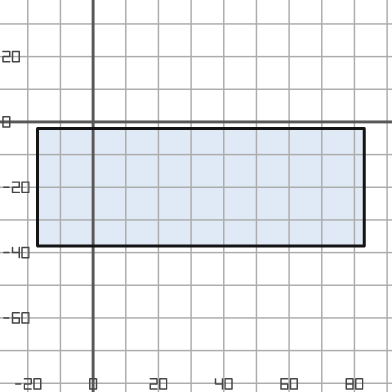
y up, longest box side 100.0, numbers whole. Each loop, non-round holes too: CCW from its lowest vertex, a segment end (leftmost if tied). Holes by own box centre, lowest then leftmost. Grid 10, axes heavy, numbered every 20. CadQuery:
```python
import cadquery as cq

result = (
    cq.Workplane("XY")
    .moveTo(-17.0, -38.0)
    .lineTo(83.0, -38.0)
    .lineTo(83.0, -2.0)
    .lineTo(-17.0, -2.0)
    .close()
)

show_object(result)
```